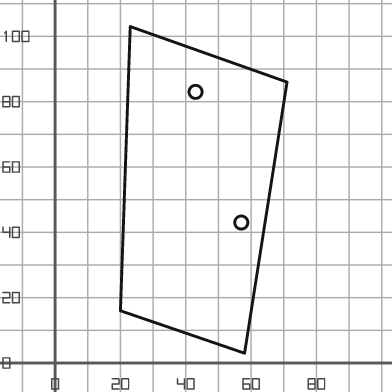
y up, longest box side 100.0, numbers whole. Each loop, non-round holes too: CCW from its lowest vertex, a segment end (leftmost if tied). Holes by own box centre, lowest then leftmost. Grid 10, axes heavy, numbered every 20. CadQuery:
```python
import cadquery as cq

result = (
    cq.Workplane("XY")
    .moveTo(58.0, 3.0)
    .lineTo(71.0, 86.0)
    .lineTo(23.0, 103.0)
    .lineTo(20.0, 16.0)
    .close()
    .moveTo(57.0, 43.0)
    .circle(2.0)
    .moveTo(43.0, 83.0)
    .circle(2.0)
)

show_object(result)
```